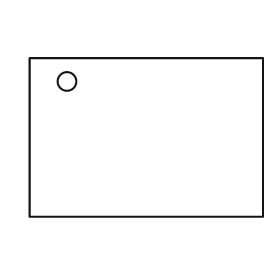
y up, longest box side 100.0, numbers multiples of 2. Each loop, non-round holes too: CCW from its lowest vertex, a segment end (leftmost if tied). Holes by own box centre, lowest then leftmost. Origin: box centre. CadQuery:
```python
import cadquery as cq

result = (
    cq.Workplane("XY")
    .moveTo(-50.0, -34.0)
    .lineTo(50.0, -34.0)
    .lineTo(50.0, 34.0)
    .lineTo(-50.0, 34.0)
    .close()
    .moveTo(-34.0, 24.0)
    .circle(4.0)
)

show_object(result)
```